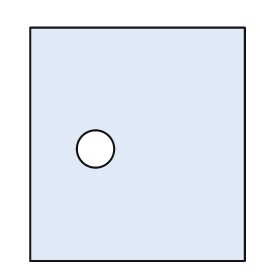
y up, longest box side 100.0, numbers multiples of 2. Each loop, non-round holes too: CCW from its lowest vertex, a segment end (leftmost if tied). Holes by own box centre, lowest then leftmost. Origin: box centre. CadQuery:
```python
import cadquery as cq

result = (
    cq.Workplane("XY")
    .moveTo(-46.0, -50.0)
    .lineTo(46.0, -50.0)
    .lineTo(46.0, 50.0)
    .lineTo(-46.0, 50.0)
    .close()
    .moveTo(-18.0, -2.0)
    .circle(8.0)
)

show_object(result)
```